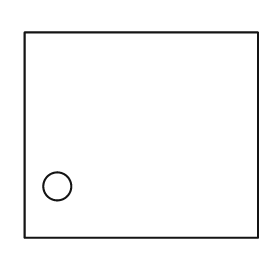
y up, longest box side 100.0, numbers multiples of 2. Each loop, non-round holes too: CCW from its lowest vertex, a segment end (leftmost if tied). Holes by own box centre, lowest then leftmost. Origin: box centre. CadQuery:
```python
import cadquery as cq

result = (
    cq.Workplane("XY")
    .moveTo(-50.0, -44.0)
    .lineTo(50.0, -44.0)
    .lineTo(50.0, 44.0)
    .lineTo(-50.0, 44.0)
    .close()
    .moveTo(-36.0, -22.0)
    .circle(6.0)
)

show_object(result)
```